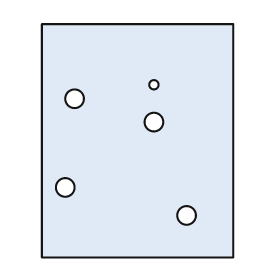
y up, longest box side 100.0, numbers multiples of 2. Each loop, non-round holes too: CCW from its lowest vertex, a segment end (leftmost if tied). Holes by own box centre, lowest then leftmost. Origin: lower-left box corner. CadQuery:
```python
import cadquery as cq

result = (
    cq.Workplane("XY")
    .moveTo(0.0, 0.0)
    .lineTo(82.0, 0.0)
    .lineTo(82.0, 100.0)
    .lineTo(0.0, 100.0)
    .close()
    .moveTo(62.0, 18.0)
    .circle(4.0)
    .moveTo(10.0, 30.0)
    .circle(4.0)
    .moveTo(48.0, 58.0)
    .circle(4.0)
    .moveTo(14.0, 68.0)
    .circle(4.0)
    .moveTo(48.0, 74.0)
    .circle(2.0)
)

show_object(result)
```